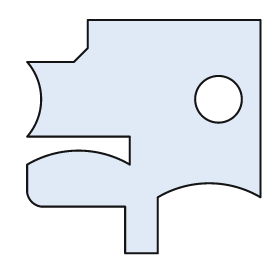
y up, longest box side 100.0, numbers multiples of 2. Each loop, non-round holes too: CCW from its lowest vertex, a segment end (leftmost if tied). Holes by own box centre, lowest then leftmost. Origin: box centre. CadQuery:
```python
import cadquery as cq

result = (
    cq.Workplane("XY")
    .moveTo(-8.0, -50.0)
    .lineTo(6.0, -50.0)
    .lineTo(6.0, -26.0)
    .threePointArc((28.0, -20.0), (50.0, -26.0))
    .lineTo(50.0, 50.0)
    .lineTo(-24.0, 50.0)
    .lineTo(-24.0, 38.0)
    .lineTo(-30.0, 32.0)
    .lineTo(-50.0, 32.0)
    .threePointArc((-44.0, 16.0), (-50.0, 0.0))
    .lineTo(-6.0, 0.0)
    .lineTo(-6.0, -12.0)
    .threePointArc((-28.0, -6.0), (-50.0, -12.0))
    .lineTo(-50.0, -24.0)
    .threePointArc((-48.0, -28.0), (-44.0, -30.0))
    .lineTo(-8.0, -30.0)
    .close()
    .moveTo(32.0, 16.0)
    .circle(10.0)
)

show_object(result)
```